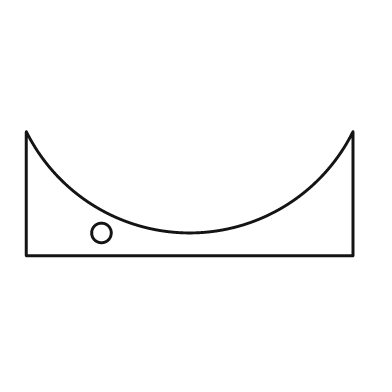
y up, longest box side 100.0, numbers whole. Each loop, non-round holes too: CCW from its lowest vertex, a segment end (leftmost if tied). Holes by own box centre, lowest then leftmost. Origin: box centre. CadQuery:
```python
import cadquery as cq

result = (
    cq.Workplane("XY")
    .moveTo(-50.0, -19.0)
    .lineTo(50.0, -19.0)
    .lineTo(50.0, 19.0)
    .threePointArc((0.0, -12.0), (-50.0, 19.0))
    .close()
    .moveTo(-27.0, -12.0)
    .circle(3.0)
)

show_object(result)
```